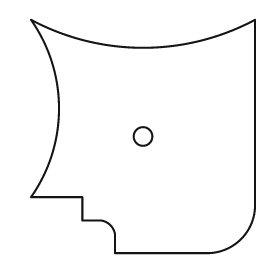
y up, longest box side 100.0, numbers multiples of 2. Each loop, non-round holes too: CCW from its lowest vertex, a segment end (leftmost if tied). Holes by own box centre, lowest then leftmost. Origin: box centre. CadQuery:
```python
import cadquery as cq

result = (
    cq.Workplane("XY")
    .moveTo(-12.0, -50.0)
    .lineTo(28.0, -50.0)
    .threePointArc((42.0, -44.0), (48.0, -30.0))
    .lineTo(48.0, 50.0)
    .threePointArc((0.0, 38.0), (-48.0, 50.0))
    .threePointArc((-36.0, 12.0), (-48.0, -26.0))
    .lineTo(-26.0, -26.0)
    .lineTo(-26.0, -36.0)
    .lineTo(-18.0, -36.0)
    .threePointArc((-14.0, -38.0), (-12.0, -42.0))
    .close()
    .moveTo(0.0, 0.0)
    .circle(4.0)
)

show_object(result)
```